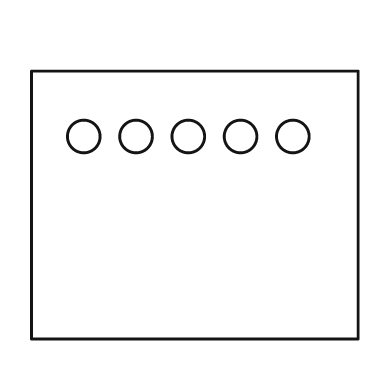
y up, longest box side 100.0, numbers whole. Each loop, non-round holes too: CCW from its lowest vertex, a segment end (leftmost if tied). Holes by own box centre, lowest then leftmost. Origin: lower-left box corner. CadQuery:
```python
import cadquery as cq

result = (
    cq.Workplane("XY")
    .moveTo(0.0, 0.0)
    .lineTo(100.0, 0.0)
    .lineTo(100.0, 82.0)
    .lineTo(0.0, 82.0)
    .close()
    .moveTo(16.0, 62.0)
    .circle(5.0)
    .moveTo(32.0, 62.0)
    .circle(5.0)
    .moveTo(48.0, 62.0)
    .circle(5.0)
    .moveTo(64.0, 62.0)
    .circle(5.0)
    .moveTo(80.0, 62.0)
    .circle(5.0)
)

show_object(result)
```